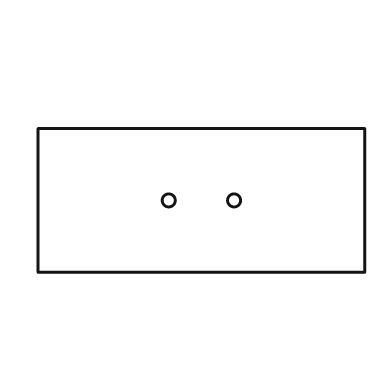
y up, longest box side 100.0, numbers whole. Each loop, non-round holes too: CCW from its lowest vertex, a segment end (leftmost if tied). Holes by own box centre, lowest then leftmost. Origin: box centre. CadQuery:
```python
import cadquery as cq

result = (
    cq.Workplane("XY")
    .moveTo(-50.0, -22.0)
    .lineTo(50.0, -22.0)
    .lineTo(50.0, 22.0)
    .lineTo(-50.0, 22.0)
    .close()
    .moveTo(-10.0, 0.0)
    .circle(2.0)
    .moveTo(10.0, 0.0)
    .circle(2.0)
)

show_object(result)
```